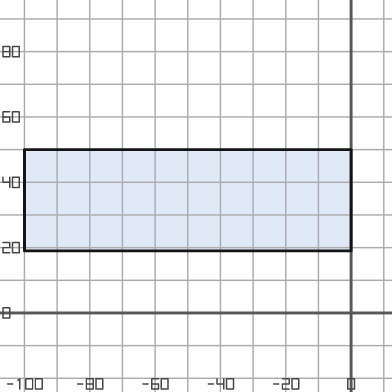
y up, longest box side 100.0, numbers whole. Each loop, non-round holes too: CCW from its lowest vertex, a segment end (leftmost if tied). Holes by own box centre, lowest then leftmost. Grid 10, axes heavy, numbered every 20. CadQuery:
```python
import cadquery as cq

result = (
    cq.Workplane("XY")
    .moveTo(-100.0, 19.0)
    .lineTo(0.0, 19.0)
    .lineTo(0.0, 50.0)
    .lineTo(-100.0, 50.0)
    .close()
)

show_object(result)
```